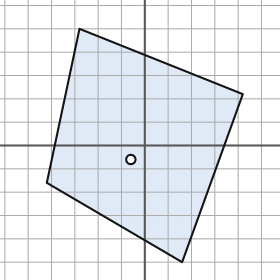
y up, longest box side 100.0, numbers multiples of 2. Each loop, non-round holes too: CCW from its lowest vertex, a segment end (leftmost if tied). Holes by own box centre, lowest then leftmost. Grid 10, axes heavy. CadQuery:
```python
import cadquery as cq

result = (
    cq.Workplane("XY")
    .moveTo(16.0, -50.0)
    .lineTo(42.0, 22.0)
    .lineTo(-28.0, 50.0)
    .lineTo(-42.0, -16.0)
    .close()
    .moveTo(-6.0, -6.0)
    .circle(2.0)
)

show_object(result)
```